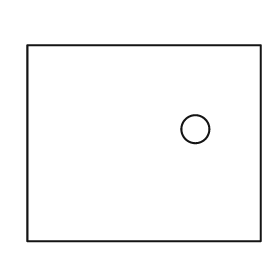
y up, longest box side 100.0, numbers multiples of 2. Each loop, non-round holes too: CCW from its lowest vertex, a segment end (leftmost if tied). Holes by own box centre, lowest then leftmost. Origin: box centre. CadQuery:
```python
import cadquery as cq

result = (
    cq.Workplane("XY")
    .moveTo(-50.0, -42.0)
    .lineTo(50.0, -42.0)
    .lineTo(50.0, 42.0)
    .lineTo(-50.0, 42.0)
    .close()
    .moveTo(22.0, 6.0)
    .circle(6.0)
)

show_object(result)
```